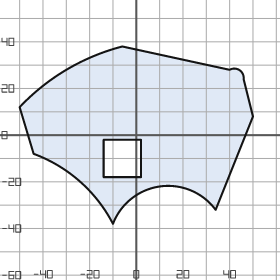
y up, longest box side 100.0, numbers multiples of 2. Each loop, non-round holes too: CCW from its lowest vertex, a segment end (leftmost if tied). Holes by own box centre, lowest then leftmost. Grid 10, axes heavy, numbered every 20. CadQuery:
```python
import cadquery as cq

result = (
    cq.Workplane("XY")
    .moveTo(-10.0, -38.0)
    .threePointArc((10.0, -22.0), (34.0, -32.0))
    .lineTo(50.0, 8.0)
    .lineTo(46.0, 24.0)
    .threePointArc((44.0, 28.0), (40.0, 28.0))
    .lineTo(-6.0, 38.0)
    .threePointArc((-30.0, 28.0), (-50.0, 12.0))
    .lineTo(-44.0, -8.0)
    .threePointArc((-24.0, -20.0), (-10.0, -38.0))
    .close()
    .moveTo(-14.0, -18.0)
    .lineTo(2.0, -18.0)
    .lineTo(2.0, -2.0)
    .lineTo(-14.0, -2.0)
    .close()
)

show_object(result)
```